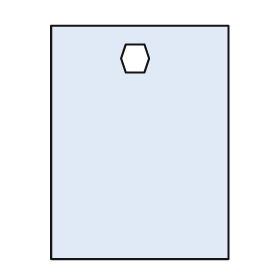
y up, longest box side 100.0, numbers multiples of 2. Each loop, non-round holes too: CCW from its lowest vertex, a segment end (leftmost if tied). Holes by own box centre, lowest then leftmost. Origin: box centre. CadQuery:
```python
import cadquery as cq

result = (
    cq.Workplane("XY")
    .moveTo(-38.0, -50.0)
    .lineTo(38.0, -50.0)
    .lineTo(38.0, 50.0)
    .lineTo(-38.0, 50.0)
    .close()
    .moveTo(-6.0, 30.0)
    .lineTo(2.0, 30.0)
    .lineTo(4.0, 36.0)
    .lineTo(2.0, 42.0)
    .lineTo(-6.0, 42.0)
    .lineTo(-8.0, 36.0)
    .close()
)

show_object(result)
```